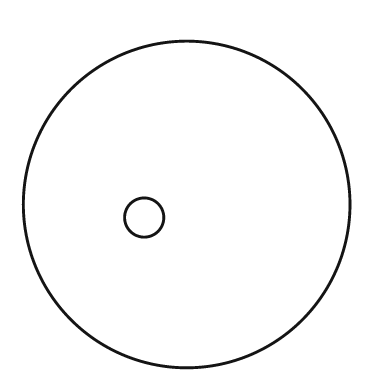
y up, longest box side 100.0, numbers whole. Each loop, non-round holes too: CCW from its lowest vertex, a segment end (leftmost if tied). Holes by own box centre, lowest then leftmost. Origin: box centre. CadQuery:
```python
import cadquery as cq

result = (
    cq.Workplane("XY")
    .moveTo(0.0, 0.0)
    .circle(50.0)
    .moveTo(-13.0, -4.0)
    .circle(6.0)
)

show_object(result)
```